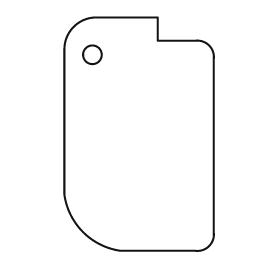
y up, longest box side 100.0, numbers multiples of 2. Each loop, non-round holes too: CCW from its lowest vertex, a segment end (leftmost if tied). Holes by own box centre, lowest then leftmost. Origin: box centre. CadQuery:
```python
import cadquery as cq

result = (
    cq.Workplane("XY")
    .moveTo(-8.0, -50.0)
    .lineTo(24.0, -50.0)
    .threePointArc((30.0, -48.0), (32.0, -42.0))
    .lineTo(32.0, 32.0)
    .threePointArc((30.0, 38.0), (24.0, 40.0))
    .lineTo(8.0, 40.0)
    .lineTo(8.0, 50.0)
    .lineTo(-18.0, 50.0)
    .threePointArc((-28.0, 46.0), (-32.0, 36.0))
    .lineTo(-32.0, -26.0)
    .threePointArc((-24.0, -42.0), (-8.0, -50.0))
    .close()
    .moveTo(-20.0, 34.0)
    .circle(4.0)
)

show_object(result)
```